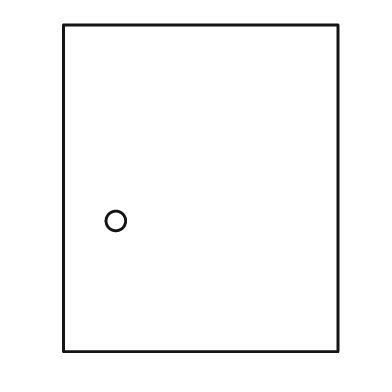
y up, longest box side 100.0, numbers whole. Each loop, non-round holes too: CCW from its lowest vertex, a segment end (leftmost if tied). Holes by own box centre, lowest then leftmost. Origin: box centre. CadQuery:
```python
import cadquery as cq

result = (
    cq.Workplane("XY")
    .moveTo(-42.0, -50.0)
    .lineTo(42.0, -50.0)
    .lineTo(42.0, 50.0)
    .lineTo(-42.0, 50.0)
    .close()
    .moveTo(-26.0, -10.0)
    .circle(3.0)
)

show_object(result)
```